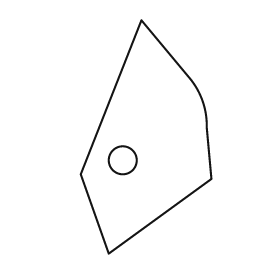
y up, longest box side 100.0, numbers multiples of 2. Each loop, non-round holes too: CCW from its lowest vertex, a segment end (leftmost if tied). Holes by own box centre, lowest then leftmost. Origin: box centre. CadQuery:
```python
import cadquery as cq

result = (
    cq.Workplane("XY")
    .moveTo(-16.0, -50.0)
    .lineTo(28.0, -18.0)
    .lineTo(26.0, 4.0)
    .threePointArc((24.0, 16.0), (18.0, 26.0))
    .lineTo(-2.0, 50.0)
    .lineTo(-28.0, -16.0)
    .close()
    .moveTo(-10.0, -10.0)
    .circle(6.0)
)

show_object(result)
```